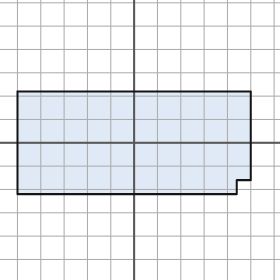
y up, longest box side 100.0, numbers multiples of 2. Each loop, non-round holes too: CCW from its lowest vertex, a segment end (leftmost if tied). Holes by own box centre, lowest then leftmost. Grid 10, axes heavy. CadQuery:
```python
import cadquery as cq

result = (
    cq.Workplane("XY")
    .moveTo(-50.0, -22.0)
    .lineTo(44.0, -22.0)
    .lineTo(44.0, -16.0)
    .lineTo(50.0, -16.0)
    .lineTo(50.0, 22.0)
    .lineTo(-50.0, 22.0)
    .close()
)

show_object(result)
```